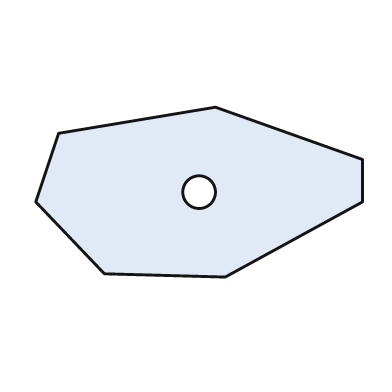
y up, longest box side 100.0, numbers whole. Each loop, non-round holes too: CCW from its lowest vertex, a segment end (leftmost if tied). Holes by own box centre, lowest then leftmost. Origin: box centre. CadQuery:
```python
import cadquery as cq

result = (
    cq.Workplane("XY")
    .moveTo(8.0, -26.0)
    .lineTo(50.0, -3.0)
    .lineTo(50.0, 10.0)
    .lineTo(5.0, 26.0)
    .lineTo(-43.0, 18.0)
    .lineTo(-50.0, -3.0)
    .lineTo(-29.0, -25.0)
    .close()
    .moveTo(0.0, 0.0)
    .circle(5.0)
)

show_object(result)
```